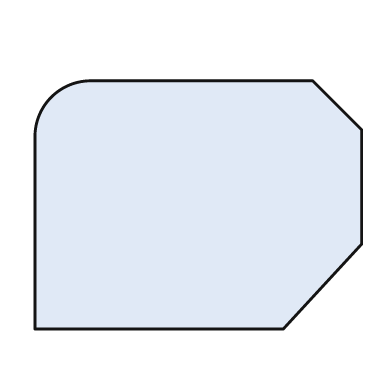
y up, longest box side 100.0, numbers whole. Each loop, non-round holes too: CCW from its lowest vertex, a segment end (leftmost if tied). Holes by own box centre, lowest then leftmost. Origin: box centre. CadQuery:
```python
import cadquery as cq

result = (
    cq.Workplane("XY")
    .moveTo(-50.0, -38.0)
    .lineTo(26.0, -38.0)
    .lineTo(50.0, -12.0)
    .lineTo(50.0, 23.0)
    .lineTo(35.0, 38.0)
    .lineTo(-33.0, 38.0)
    .threePointArc((-45.0, 33.0), (-50.0, 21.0))
    .close()
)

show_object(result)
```